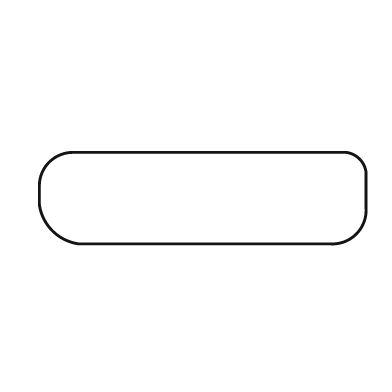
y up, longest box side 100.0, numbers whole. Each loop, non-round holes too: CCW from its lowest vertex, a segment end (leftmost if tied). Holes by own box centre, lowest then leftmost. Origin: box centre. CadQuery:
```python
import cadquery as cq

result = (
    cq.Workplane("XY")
    .moveTo(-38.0, -14.0)
    .lineTo(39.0, -14.0)
    .threePointArc((47.0, -11.0), (50.0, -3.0))
    .lineTo(50.0, 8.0)
    .threePointArc((48.0, 12.0), (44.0, 14.0))
    .lineTo(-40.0, 14.0)
    .threePointArc((-47.0, 11.0), (-50.0, 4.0))
    .lineTo(-50.0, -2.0)
    .threePointArc((-46.0, -10.0), (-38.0, -14.0))
    .close()
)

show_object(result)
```